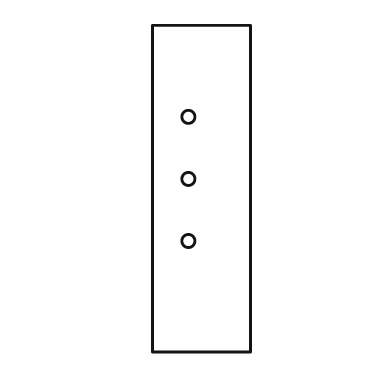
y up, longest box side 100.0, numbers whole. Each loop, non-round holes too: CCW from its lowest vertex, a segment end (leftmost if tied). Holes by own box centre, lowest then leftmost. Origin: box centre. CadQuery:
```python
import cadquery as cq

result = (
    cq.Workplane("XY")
    .moveTo(-15.0, -50.0)
    .lineTo(15.0, -50.0)
    .lineTo(15.0, 50.0)
    .lineTo(-15.0, 50.0)
    .close()
    .moveTo(-4.0, -16.0)
    .circle(2.0)
    .moveTo(-4.0, 3.0)
    .circle(2.0)
    .moveTo(-4.0, 22.0)
    .circle(2.0)
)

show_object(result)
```